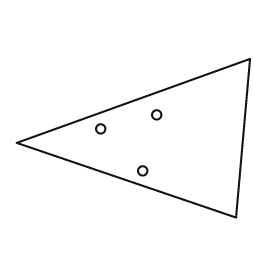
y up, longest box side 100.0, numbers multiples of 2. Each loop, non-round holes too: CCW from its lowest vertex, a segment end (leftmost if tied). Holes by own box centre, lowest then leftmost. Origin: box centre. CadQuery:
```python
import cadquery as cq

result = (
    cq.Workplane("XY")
    .moveTo(44.0, -34.0)
    .lineTo(50.0, 34.0)
    .lineTo(-50.0, -2.0)
    .close()
    .moveTo(4.0, -14.0)
    .circle(2.0)
    .moveTo(-14.0, 4.0)
    .circle(2.0)
    .moveTo(10.0, 10.0)
    .circle(2.0)
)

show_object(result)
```